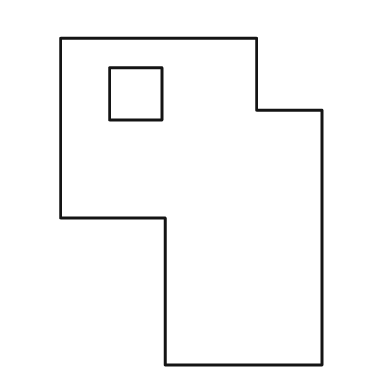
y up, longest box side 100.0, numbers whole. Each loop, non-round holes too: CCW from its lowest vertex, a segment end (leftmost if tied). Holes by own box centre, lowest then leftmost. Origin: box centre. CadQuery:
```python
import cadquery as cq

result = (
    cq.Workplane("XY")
    .moveTo(-8.0, -50.0)
    .lineTo(40.0, -50.0)
    .lineTo(40.0, 28.0)
    .lineTo(20.0, 28.0)
    .lineTo(20.0, 50.0)
    .lineTo(-40.0, 50.0)
    .lineTo(-40.0, -5.0)
    .lineTo(-8.0, -5.0)
    .close()
    .moveTo(-25.0, 25.0)
    .lineTo(-9.0, 25.0)
    .lineTo(-9.0, 41.0)
    .lineTo(-25.0, 41.0)
    .close()
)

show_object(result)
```